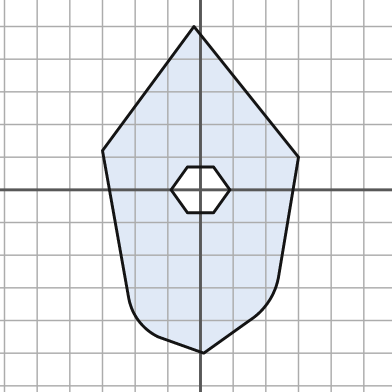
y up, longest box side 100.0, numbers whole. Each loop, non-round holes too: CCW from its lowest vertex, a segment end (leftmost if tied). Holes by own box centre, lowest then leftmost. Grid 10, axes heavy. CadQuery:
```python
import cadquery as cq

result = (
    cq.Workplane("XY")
    .moveTo(1.0, -50.0)
    .lineTo(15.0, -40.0)
    .threePointArc((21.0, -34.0), (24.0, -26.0))
    .lineTo(30.0, 10.0)
    .lineTo(-2.0, 50.0)
    .lineTo(-30.0, 12.0)
    .lineTo(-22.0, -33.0)
    .threePointArc((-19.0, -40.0), (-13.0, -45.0))
    .close()
    .moveTo(-4.0, -7.0)
    .lineTo(4.0, -7.0)
    .lineTo(9.0, 0.0)
    .lineTo(4.0, 7.0)
    .lineTo(-4.0, 7.0)
    .lineTo(-9.0, 0.0)
    .close()
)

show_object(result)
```